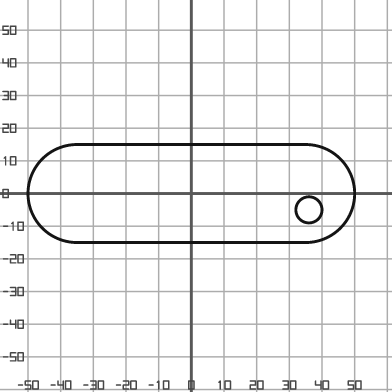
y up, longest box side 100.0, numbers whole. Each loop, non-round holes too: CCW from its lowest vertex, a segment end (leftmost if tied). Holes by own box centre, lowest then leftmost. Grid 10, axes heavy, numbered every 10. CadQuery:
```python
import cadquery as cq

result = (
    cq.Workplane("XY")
    .moveTo(-35.0, -15.0)
    .lineTo(35.0, -15.0)
    .threePointArc((50.0, 0.0), (35.0, 15.0))
    .lineTo(-35.0, 15.0)
    .threePointArc((-50.0, 0.0), (-35.0, -15.0))
    .close()
    .moveTo(36.0, -5.0)
    .circle(4.0)
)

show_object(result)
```